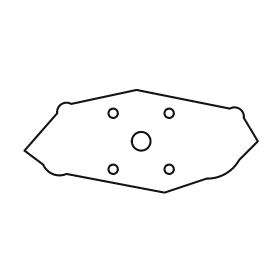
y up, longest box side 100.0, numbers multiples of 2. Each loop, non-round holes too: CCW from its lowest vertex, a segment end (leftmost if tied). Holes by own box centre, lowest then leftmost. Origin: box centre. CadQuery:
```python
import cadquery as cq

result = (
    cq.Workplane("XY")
    .moveTo(10.0, -22.0)
    .lineTo(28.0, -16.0)
    .threePointArc((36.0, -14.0), (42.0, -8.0))
    .lineTo(50.0, 0.0)
    .lineTo(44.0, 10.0)
    .threePointArc((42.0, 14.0), (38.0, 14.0))
    .lineTo(-2.0, 22.0)
    .lineTo(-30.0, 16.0)
    .threePointArc((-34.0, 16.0), (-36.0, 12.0))
    .lineTo(-50.0, -4.0)
    .lineTo(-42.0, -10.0)
    .threePointArc((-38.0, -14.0), (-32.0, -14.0))
    .close()
    .moveTo(-12.0, -12.0)
    .circle(2.0)
    .moveTo(12.0, -12.0)
    .circle(2.0)
    .moveTo(0.0, 0.0)
    .circle(4.0)
    .moveTo(-12.0, 12.0)
    .circle(2.0)
    .moveTo(12.0, 12.0)
    .circle(2.0)
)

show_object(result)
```